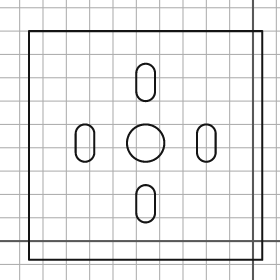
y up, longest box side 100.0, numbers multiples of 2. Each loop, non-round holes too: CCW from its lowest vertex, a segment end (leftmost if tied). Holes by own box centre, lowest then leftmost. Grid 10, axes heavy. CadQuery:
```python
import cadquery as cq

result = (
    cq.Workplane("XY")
    .moveTo(-96.0, -8.0)
    .lineTo(4.0, -8.0)
    .lineTo(4.0, 90.0)
    .lineTo(-96.0, 90.0)
    .close()
    .moveTo(-50.0, 12.0)
    .threePointArc((-46.0, 8.0), (-42.0, 12.0))
    .lineTo(-42.0, 20.0)
    .threePointArc((-46.0, 24.0), (-50.0, 20.0))
    .close()
    .moveTo(-76.0, 38.0)
    .threePointArc((-72.0, 34.0), (-68.0, 38.0))
    .lineTo(-68.0, 46.0)
    .threePointArc((-72.0, 50.0), (-76.0, 46.0))
    .close()
    .moveTo(-46.0, 42.0)
    .circle(8.0)
    .moveTo(-24.0, 38.0)
    .threePointArc((-20.0, 34.0), (-16.0, 38.0))
    .lineTo(-16.0, 46.0)
    .threePointArc((-20.0, 50.0), (-24.0, 46.0))
    .close()
    .moveTo(-50.0, 64.0)
    .threePointArc((-46.0, 60.0), (-42.0, 64.0))
    .lineTo(-42.0, 72.0)
    .threePointArc((-46.0, 76.0), (-50.0, 72.0))
    .close()
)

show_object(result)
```